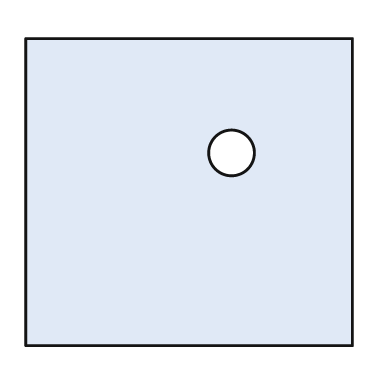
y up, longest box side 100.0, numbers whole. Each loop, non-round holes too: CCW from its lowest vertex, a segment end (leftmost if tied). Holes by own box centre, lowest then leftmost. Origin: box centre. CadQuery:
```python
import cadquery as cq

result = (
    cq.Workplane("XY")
    .moveTo(-50.0, -47.0)
    .lineTo(50.0, -47.0)
    .lineTo(50.0, 47.0)
    .lineTo(-50.0, 47.0)
    .close()
    .moveTo(13.0, 12.0)
    .circle(7.0)
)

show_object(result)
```